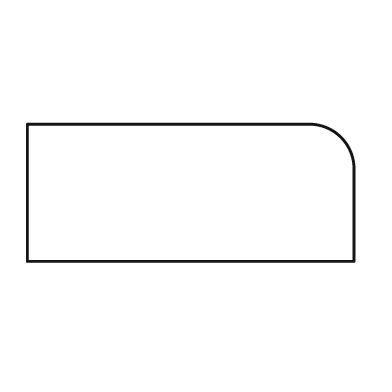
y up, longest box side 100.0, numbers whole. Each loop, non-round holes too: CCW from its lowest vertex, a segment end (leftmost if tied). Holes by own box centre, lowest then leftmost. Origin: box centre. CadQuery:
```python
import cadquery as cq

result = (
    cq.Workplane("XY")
    .moveTo(-50.0, -21.0)
    .lineTo(50.0, -21.0)
    .lineTo(50.0, 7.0)
    .threePointArc((46.0, 17.0), (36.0, 21.0))
    .lineTo(-50.0, 21.0)
    .close()
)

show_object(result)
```